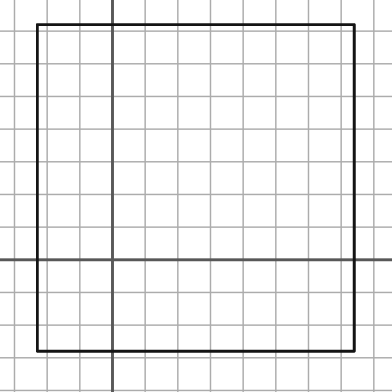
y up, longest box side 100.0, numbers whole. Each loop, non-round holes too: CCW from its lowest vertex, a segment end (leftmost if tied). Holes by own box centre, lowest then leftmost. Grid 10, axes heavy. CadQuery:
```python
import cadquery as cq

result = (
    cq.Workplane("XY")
    .moveTo(-23.0, -28.0)
    .lineTo(74.0, -28.0)
    .lineTo(74.0, 72.0)
    .lineTo(-23.0, 72.0)
    .close()
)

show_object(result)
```